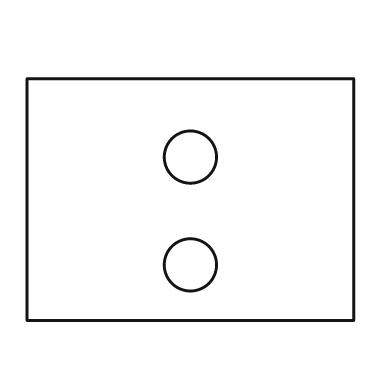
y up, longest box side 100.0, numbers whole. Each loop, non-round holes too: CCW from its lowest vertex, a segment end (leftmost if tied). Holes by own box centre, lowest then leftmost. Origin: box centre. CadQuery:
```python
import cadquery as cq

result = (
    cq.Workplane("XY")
    .moveTo(-50.0, -37.0)
    .lineTo(50.0, -37.0)
    .lineTo(50.0, 37.0)
    .lineTo(-50.0, 37.0)
    .close()
    .moveTo(0.0, -20.0)
    .circle(8.0)
    .moveTo(0.0, 13.0)
    .circle(8.0)
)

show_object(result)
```